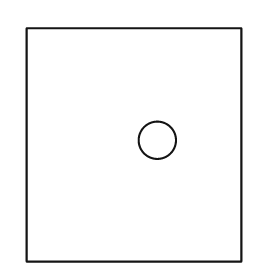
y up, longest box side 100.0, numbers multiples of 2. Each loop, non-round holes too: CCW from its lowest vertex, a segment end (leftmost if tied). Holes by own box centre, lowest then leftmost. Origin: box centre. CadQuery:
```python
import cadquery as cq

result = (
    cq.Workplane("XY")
    .moveTo(-46.0, -50.0)
    .lineTo(46.0, -50.0)
    .lineTo(46.0, 50.0)
    .lineTo(-46.0, 50.0)
    .close()
    .moveTo(10.0, 2.0)
    .circle(8.0)
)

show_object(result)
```